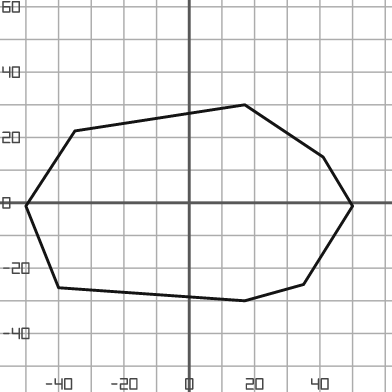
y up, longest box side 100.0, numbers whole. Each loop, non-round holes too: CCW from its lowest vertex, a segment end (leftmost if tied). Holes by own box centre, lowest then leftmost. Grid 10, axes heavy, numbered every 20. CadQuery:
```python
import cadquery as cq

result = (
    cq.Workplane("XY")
    .moveTo(17.0, -30.0)
    .lineTo(35.0, -25.0)
    .lineTo(50.0, -1.0)
    .lineTo(41.0, 14.0)
    .lineTo(17.0, 30.0)
    .lineTo(-35.0, 22.0)
    .lineTo(-50.0, -1.0)
    .lineTo(-40.0, -26.0)
    .close()
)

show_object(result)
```